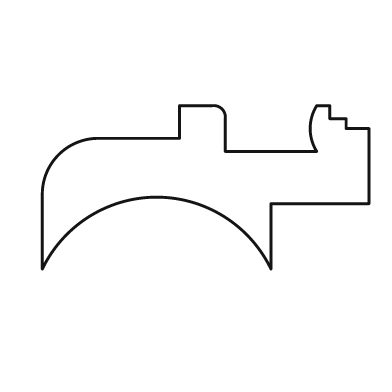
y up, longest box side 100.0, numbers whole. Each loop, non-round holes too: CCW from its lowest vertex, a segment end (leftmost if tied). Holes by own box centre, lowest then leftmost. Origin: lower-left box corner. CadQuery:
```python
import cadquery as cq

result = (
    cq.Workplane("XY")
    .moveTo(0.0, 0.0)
    .threePointArc((35.0, 22.0), (70.0, 0.0))
    .lineTo(70.0, 20.0)
    .lineTo(100.0, 20.0)
    .lineTo(100.0, 43.0)
    .lineTo(93.0, 43.0)
    .lineTo(93.0, 46.0)
    .lineTo(88.0, 46.0)
    .lineTo(88.0, 50.0)
    .lineTo(84.0, 50.0)
    .threePointArc((82.0, 43.0), (84.0, 36.0))
    .lineTo(56.0, 36.0)
    .lineTo(56.0, 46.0)
    .threePointArc((55.0, 49.0), (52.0, 50.0))
    .lineTo(42.0, 50.0)
    .lineTo(42.0, 40.0)
    .lineTo(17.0, 40.0)
    .threePointArc((5.0, 35.0), (0.0, 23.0))
    .close()
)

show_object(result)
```